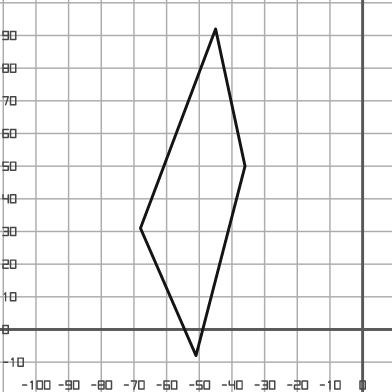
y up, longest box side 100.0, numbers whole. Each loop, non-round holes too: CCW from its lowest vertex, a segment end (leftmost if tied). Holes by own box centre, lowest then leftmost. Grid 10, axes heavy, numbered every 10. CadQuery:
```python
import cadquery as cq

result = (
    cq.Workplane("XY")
    .moveTo(-51.0, -8.0)
    .lineTo(-36.0, 50.0)
    .lineTo(-45.0, 92.0)
    .lineTo(-68.0, 31.0)
    .close()
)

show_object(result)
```